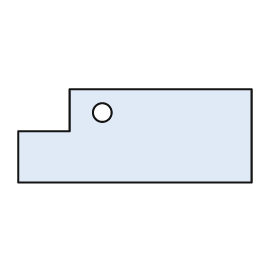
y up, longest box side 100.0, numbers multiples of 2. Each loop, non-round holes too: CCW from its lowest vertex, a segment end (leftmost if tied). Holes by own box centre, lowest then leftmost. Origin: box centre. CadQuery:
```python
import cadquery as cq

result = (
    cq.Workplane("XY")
    .moveTo(-50.0, -20.0)
    .lineTo(50.0, -20.0)
    .lineTo(50.0, 20.0)
    .lineTo(-28.0, 20.0)
    .lineTo(-28.0, 2.0)
    .lineTo(-50.0, 2.0)
    .close()
    .moveTo(-14.0, 10.0)
    .circle(4.0)
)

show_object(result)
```